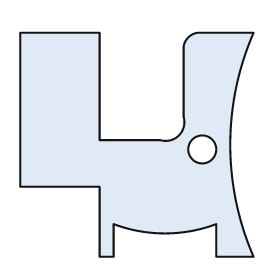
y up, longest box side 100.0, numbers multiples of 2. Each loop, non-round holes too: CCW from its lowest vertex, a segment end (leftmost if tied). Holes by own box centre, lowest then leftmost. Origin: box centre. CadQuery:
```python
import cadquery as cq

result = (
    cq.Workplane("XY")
    .moveTo(-16.0, -48.0)
    .lineTo(-10.0, -48.0)
    .lineTo(-10.0, -34.0)
    .threePointArc((12.0, -38.0), (34.0, -34.0))
    .lineTo(34.0, -48.0)
    .lineTo(50.0, -48.0)
    .threePointArc((40.0, 0.0), (50.0, 48.0))
    .lineTo(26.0, 48.0)
    .threePointArc((22.0, 46.0), (20.0, 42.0))
    .lineTo(20.0, 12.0)
    .threePointArc((18.0, 4.0), (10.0, 2.0))
    .lineTo(-16.0, 2.0)
    .lineTo(-16.0, 48.0)
    .lineTo(-50.0, 48.0)
    .lineTo(-50.0, -18.0)
    .lineTo(-16.0, -18.0)
    .close()
    .moveTo(28.0, -2.0)
    .circle(6.0)
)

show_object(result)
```